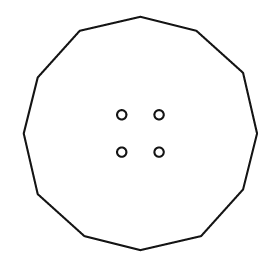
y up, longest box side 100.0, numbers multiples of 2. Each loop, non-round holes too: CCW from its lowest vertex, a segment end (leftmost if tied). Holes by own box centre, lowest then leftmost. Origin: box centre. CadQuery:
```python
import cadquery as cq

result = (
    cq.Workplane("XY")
    .moveTo(0.0, -50.0)
    .lineTo(26.0, -44.0)
    .lineTo(44.0, -24.0)
    .lineTo(50.0, 0.0)
    .lineTo(44.0, 26.0)
    .lineTo(24.0, 44.0)
    .lineTo(0.0, 50.0)
    .lineTo(-26.0, 44.0)
    .lineTo(-44.0, 24.0)
    .lineTo(-50.0, 0.0)
    .lineTo(-44.0, -26.0)
    .lineTo(-24.0, -44.0)
    .close()
    .moveTo(-8.0, -8.0)
    .circle(2.0)
    .moveTo(8.0, -8.0)
    .circle(2.0)
    .moveTo(-8.0, 8.0)
    .circle(2.0)
    .moveTo(8.0, 8.0)
    .circle(2.0)
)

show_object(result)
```